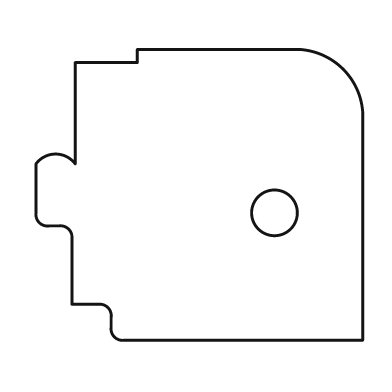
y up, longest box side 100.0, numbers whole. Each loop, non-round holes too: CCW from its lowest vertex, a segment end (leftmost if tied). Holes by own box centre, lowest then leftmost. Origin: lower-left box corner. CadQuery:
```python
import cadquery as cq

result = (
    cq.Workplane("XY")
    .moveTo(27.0, 0.0)
    .lineTo(100.0, 0.0)
    .lineTo(100.0, 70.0)
    .threePointArc((94.0, 83.0), (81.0, 89.0))
    .lineTo(31.0, 89.0)
    .lineTo(31.0, 85.0)
    .lineTo(12.0, 85.0)
    .lineTo(12.0, 54.0)
    .threePointArc((6.0, 57.0), (0.0, 54.0))
    .lineTo(0.0, 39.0)
    .threePointArc((1.0, 36.0), (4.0, 35.0))
    .lineTo(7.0, 35.0)
    .threePointArc((10.0, 34.0), (11.0, 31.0))
    .lineTo(11.0, 11.0)
    .lineTo(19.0, 11.0)
    .threePointArc((22.0, 10.0), (23.0, 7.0))
    .lineTo(23.0, 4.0)
    .threePointArc((24.0, 1.0), (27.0, 0.0))
    .close()
    .moveTo(73.0, 39.0)
    .circle(7.0)
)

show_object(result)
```